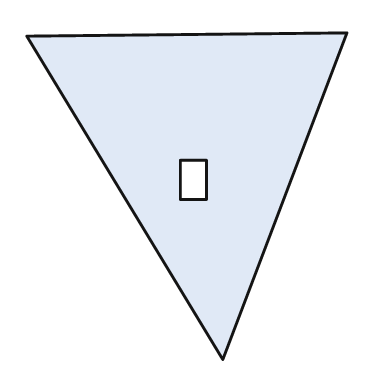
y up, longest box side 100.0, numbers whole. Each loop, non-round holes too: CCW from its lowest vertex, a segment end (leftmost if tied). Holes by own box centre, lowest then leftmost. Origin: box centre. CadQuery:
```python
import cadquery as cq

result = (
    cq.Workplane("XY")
    .moveTo(11.0, -50.0)
    .lineTo(49.0, 50.0)
    .lineTo(-49.0, 49.0)
    .close()
    .moveTo(-2.0, -1.0)
    .lineTo(6.0, -1.0)
    .lineTo(6.0, 11.0)
    .lineTo(-2.0, 11.0)
    .close()
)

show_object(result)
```